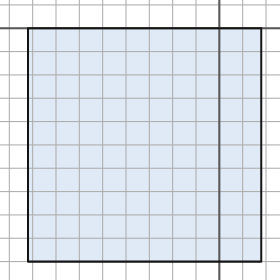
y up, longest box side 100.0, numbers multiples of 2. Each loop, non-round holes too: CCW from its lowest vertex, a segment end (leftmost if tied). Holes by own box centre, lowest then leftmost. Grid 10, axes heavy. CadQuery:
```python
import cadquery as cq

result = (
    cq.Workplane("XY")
    .moveTo(-82.0, -100.0)
    .lineTo(18.0, -100.0)
    .lineTo(18.0, 0.0)
    .lineTo(-82.0, 0.0)
    .close()
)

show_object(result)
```